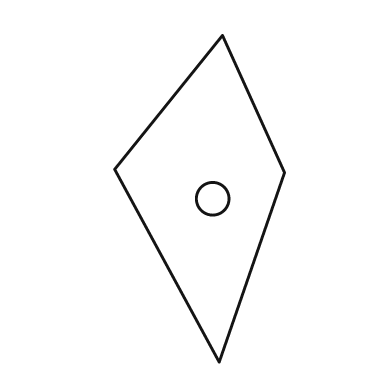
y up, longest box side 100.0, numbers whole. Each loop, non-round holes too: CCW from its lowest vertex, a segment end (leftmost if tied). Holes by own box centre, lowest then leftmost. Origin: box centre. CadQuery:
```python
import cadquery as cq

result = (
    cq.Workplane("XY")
    .moveTo(6.0, -50.0)
    .lineTo(26.0, 8.0)
    .lineTo(7.0, 50.0)
    .lineTo(-26.0, 9.0)
    .close()
    .moveTo(4.0, 0.0)
    .circle(5.0)
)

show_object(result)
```